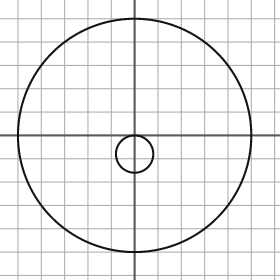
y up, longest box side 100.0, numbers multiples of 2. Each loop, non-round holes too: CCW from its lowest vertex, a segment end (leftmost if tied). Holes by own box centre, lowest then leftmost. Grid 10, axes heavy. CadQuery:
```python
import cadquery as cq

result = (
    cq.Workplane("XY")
    .moveTo(0.0, 0.0)
    .circle(50.0)
    .moveTo(0.0, -8.0)
    .circle(8.0)
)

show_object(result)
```